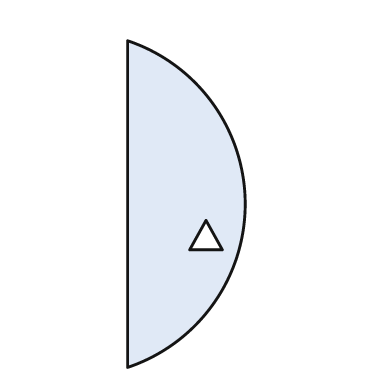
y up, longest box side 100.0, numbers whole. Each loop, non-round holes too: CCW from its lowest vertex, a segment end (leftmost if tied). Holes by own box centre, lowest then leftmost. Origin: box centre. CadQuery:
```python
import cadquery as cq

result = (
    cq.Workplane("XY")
    .moveTo(-18.0, -50.0)
    .threePointArc((18.0, 0.0), (-18.0, 50.0))
    .close()
    .moveTo(1.0, -14.0)
    .lineTo(11.0, -14.0)
    .lineTo(6.0, -5.0)
    .close()
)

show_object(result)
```